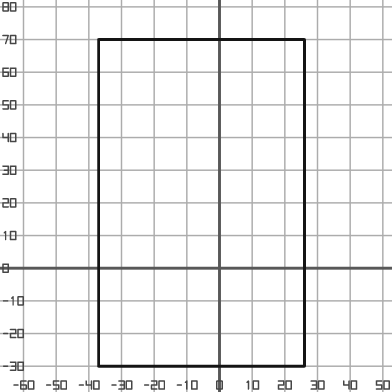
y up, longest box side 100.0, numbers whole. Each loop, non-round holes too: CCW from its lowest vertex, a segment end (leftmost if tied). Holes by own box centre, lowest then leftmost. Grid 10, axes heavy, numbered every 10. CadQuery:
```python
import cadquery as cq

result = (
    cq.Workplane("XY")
    .moveTo(-37.0, -30.0)
    .lineTo(26.0, -30.0)
    .lineTo(26.0, 70.0)
    .lineTo(-37.0, 70.0)
    .close()
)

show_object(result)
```